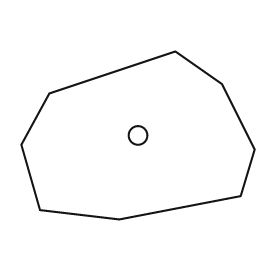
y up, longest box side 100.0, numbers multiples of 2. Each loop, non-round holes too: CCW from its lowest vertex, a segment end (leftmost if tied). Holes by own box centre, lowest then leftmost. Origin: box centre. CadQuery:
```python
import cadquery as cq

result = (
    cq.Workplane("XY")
    .moveTo(-8.0, -36.0)
    .lineTo(44.0, -26.0)
    .lineTo(50.0, -6.0)
    .lineTo(36.0, 22.0)
    .lineTo(16.0, 36.0)
    .lineTo(-38.0, 18.0)
    .lineTo(-50.0, -4.0)
    .lineTo(-42.0, -32.0)
    .close()
    .moveTo(0.0, 0.0)
    .circle(4.0)
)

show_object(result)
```